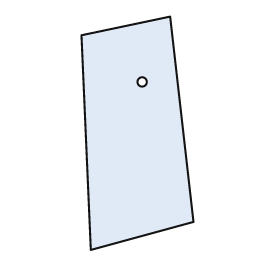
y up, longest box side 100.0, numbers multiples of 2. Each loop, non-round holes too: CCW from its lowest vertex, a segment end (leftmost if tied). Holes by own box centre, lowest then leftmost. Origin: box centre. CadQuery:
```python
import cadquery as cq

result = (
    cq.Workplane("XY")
    .moveTo(-20.0, -50.0)
    .lineTo(24.0, -38.0)
    .lineTo(14.0, 50.0)
    .lineTo(-24.0, 42.0)
    .close()
    .moveTo(2.0, 22.0)
    .circle(2.0)
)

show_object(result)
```